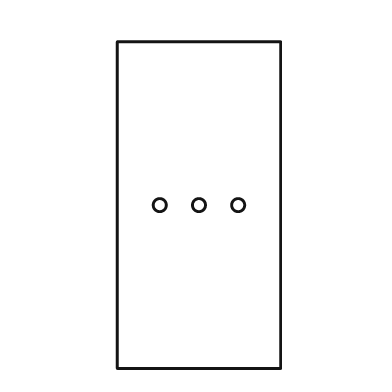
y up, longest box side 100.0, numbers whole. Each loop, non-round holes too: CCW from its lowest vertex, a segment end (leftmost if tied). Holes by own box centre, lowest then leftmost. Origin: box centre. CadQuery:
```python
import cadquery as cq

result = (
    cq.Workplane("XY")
    .moveTo(-25.0, -50.0)
    .lineTo(25.0, -50.0)
    .lineTo(25.0, 50.0)
    .lineTo(-25.0, 50.0)
    .close()
    .moveTo(-12.0, 0.0)
    .circle(2.0)
    .moveTo(0.0, 0.0)
    .circle(2.0)
    .moveTo(12.0, 0.0)
    .circle(2.0)
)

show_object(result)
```